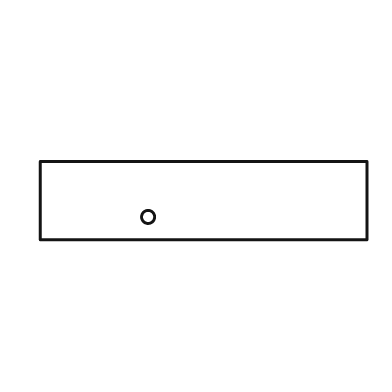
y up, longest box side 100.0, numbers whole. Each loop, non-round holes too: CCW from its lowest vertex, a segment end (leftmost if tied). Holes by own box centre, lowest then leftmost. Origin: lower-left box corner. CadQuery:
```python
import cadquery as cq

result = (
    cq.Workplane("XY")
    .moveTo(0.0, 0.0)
    .lineTo(100.0, 0.0)
    .lineTo(100.0, 24.0)
    .lineTo(0.0, 24.0)
    .close()
    .moveTo(33.0, 7.0)
    .circle(2.0)
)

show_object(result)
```